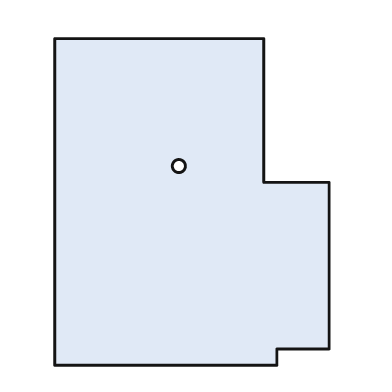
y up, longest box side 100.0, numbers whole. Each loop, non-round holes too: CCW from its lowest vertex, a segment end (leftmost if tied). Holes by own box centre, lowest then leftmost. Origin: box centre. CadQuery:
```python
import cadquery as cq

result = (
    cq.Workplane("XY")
    .moveTo(-42.0, -50.0)
    .lineTo(26.0, -50.0)
    .lineTo(26.0, -45.0)
    .lineTo(42.0, -45.0)
    .lineTo(42.0, 6.0)
    .lineTo(22.0, 6.0)
    .lineTo(22.0, 50.0)
    .lineTo(-42.0, 50.0)
    .close()
    .moveTo(-4.0, 11.0)
    .circle(2.0)
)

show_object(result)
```